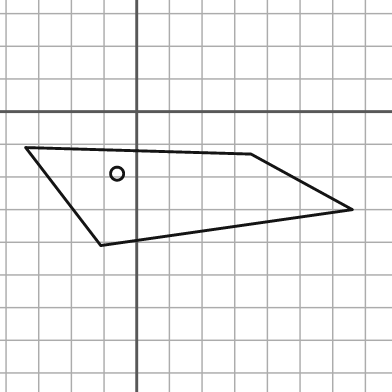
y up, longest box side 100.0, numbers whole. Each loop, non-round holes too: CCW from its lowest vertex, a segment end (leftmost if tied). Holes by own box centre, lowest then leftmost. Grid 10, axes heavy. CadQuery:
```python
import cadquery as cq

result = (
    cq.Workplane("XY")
    .moveTo(-11.0, -41.0)
    .lineTo(66.0, -30.0)
    .lineTo(35.0, -13.0)
    .lineTo(-34.0, -11.0)
    .close()
    .moveTo(-6.0, -19.0)
    .circle(2.0)
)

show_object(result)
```